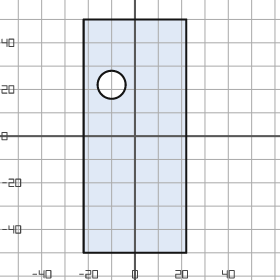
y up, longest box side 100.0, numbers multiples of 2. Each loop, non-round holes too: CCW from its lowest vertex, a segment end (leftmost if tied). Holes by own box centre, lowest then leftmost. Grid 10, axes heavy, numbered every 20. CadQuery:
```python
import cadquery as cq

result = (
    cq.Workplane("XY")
    .moveTo(-22.0, -50.0)
    .lineTo(22.0, -50.0)
    .lineTo(22.0, 50.0)
    .lineTo(-22.0, 50.0)
    .close()
    .moveTo(-10.0, 22.0)
    .circle(6.0)
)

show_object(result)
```